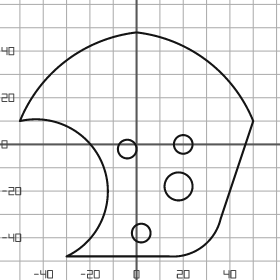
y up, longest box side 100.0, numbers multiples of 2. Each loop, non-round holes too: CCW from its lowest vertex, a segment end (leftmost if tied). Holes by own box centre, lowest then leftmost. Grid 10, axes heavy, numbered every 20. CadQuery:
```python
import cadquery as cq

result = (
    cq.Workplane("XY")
    .moveTo(-30.0, -48.0)
    .lineTo(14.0, -48.0)
    .threePointArc((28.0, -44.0), (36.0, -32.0))
    .lineTo(50.0, 10.0)
    .threePointArc((30.0, 36.0), (0.0, 48.0))
    .threePointArc((-30.0, 36.0), (-50.0, 10.0))
    .threePointArc((-14.0, -10.0), (-30.0, -48.0))
    .close()
    .moveTo(2.0, -38.0)
    .circle(4.0)
    .moveTo(18.0, -18.0)
    .circle(6.0)
    .moveTo(-4.0, -2.0)
    .circle(4.0)
    .moveTo(20.0, 0.0)
    .circle(4.0)
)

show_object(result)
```